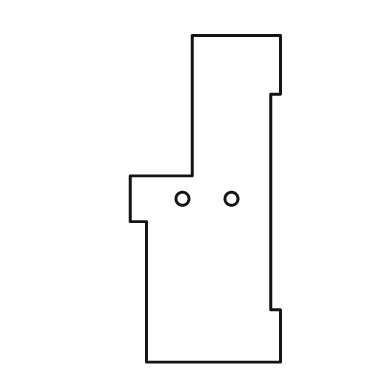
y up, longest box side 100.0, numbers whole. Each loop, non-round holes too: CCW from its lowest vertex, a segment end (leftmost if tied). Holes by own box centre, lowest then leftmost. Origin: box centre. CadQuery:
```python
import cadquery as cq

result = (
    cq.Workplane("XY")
    .moveTo(-18.0, -50.0)
    .lineTo(23.0, -50.0)
    .lineTo(23.0, -34.0)
    .lineTo(20.0, -34.0)
    .lineTo(20.0, 32.0)
    .lineTo(23.0, 32.0)
    .lineTo(23.0, 50.0)
    .lineTo(-4.0, 50.0)
    .lineTo(-4.0, 7.0)
    .lineTo(-23.0, 7.0)
    .lineTo(-23.0, -7.0)
    .lineTo(-18.0, -7.0)
    .close()
    .moveTo(-7.0, 0.0)
    .circle(2.0)
    .moveTo(8.0, 0.0)
    .circle(2.0)
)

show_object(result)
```